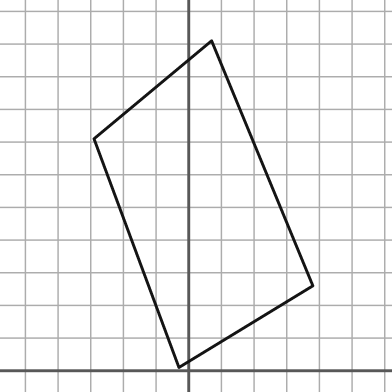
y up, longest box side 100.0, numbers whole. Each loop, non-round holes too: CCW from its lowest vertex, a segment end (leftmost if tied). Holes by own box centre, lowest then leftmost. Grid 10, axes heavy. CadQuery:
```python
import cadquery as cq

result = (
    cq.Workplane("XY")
    .moveTo(-3.0, 1.0)
    .lineTo(38.0, 26.0)
    .lineTo(7.0, 101.0)
    .lineTo(-29.0, 71.0)
    .close()
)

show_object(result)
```